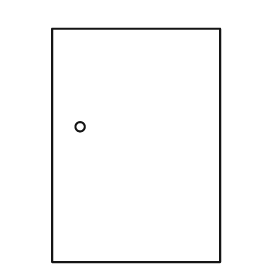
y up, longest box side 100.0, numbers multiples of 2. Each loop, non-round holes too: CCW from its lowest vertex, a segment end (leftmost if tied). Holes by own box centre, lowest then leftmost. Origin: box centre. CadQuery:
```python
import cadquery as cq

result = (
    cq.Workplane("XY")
    .moveTo(-36.0, -50.0)
    .lineTo(36.0, -50.0)
    .lineTo(36.0, 50.0)
    .lineTo(-36.0, 50.0)
    .close()
    .moveTo(-24.0, 8.0)
    .circle(2.0)
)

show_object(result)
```